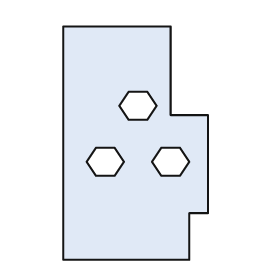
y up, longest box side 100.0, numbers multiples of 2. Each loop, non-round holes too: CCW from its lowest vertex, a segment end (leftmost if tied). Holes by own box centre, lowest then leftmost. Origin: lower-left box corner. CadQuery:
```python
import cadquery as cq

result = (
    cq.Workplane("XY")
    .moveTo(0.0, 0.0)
    .lineTo(54.0, 0.0)
    .lineTo(54.0, 20.0)
    .lineTo(62.0, 20.0)
    .lineTo(62.0, 62.0)
    .lineTo(46.0, 62.0)
    .lineTo(46.0, 100.0)
    .lineTo(0.0, 100.0)
    .close()
    .moveTo(14.0, 36.0)
    .lineTo(22.0, 36.0)
    .lineTo(26.0, 42.0)
    .lineTo(22.0, 48.0)
    .lineTo(14.0, 48.0)
    .lineTo(10.0, 42.0)
    .close()
    .moveTo(42.0, 36.0)
    .lineTo(50.0, 36.0)
    .lineTo(54.0, 42.0)
    .lineTo(50.0, 48.0)
    .lineTo(42.0, 48.0)
    .lineTo(38.0, 42.0)
    .close()
    .moveTo(28.0, 60.0)
    .lineTo(36.0, 60.0)
    .lineTo(40.0, 66.0)
    .lineTo(36.0, 72.0)
    .lineTo(28.0, 72.0)
    .lineTo(24.0, 66.0)
    .close()
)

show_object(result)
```